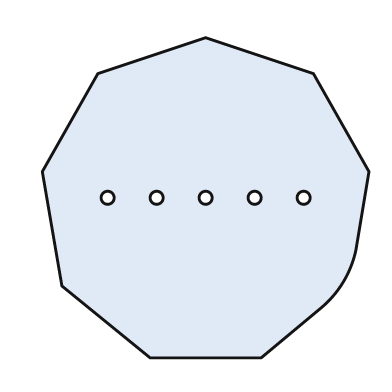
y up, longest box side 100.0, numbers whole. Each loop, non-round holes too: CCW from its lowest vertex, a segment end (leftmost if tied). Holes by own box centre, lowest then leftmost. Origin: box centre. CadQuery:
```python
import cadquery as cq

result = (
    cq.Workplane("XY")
    .moveTo(-17.0, -49.0)
    .lineTo(17.0, -49.0)
    .lineTo(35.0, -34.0)
    .threePointArc((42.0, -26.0), (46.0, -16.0))
    .lineTo(50.0, 8.0)
    .lineTo(33.0, 38.0)
    .lineTo(0.0, 49.0)
    .lineTo(-33.0, 38.0)
    .lineTo(-50.0, 8.0)
    .lineTo(-44.0, -27.0)
    .close()
    .moveTo(-30.0, 0.0)
    .circle(2.0)
    .moveTo(-15.0, 0.0)
    .circle(2.0)
    .moveTo(0.0, 0.0)
    .circle(2.0)
    .moveTo(15.0, 0.0)
    .circle(2.0)
    .moveTo(30.0, 0.0)
    .circle(2.0)
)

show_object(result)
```